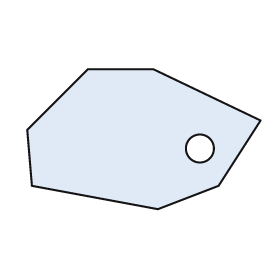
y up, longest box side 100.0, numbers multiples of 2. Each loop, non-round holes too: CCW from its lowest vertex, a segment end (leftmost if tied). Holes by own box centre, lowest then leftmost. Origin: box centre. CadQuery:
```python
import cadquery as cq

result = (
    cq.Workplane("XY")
    .moveTo(6.0, -30.0)
    .lineTo(32.0, -20.0)
    .lineTo(50.0, 8.0)
    .lineTo(4.0, 30.0)
    .lineTo(-24.0, 30.0)
    .lineTo(-50.0, 4.0)
    .lineTo(-48.0, -20.0)
    .close()
    .moveTo(24.0, -4.0)
    .circle(6.0)
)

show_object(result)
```